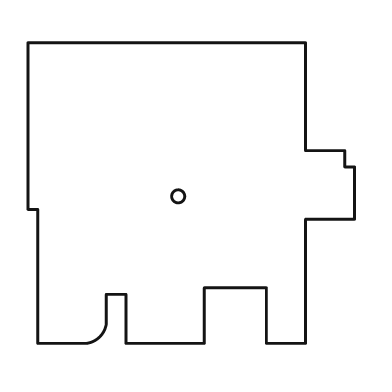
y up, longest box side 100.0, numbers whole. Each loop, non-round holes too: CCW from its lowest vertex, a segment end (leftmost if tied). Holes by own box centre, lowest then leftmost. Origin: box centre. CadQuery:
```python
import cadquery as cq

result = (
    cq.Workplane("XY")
    .moveTo(-47.0, -46.0)
    .lineTo(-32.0, -46.0)
    .threePointArc((-28.0, -44.0), (-26.0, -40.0))
    .lineTo(-26.0, -31.0)
    .lineTo(-20.0, -31.0)
    .lineTo(-20.0, -46.0)
    .lineTo(4.0, -46.0)
    .lineTo(4.0, -29.0)
    .lineTo(23.0, -29.0)
    .lineTo(23.0, -46.0)
    .lineTo(35.0, -46.0)
    .lineTo(35.0, -8.0)
    .lineTo(50.0, -8.0)
    .lineTo(50.0, 8.0)
    .lineTo(47.0, 8.0)
    .lineTo(47.0, 13.0)
    .lineTo(35.0, 13.0)
    .lineTo(35.0, 46.0)
    .lineTo(-50.0, 46.0)
    .lineTo(-50.0, -5.0)
    .lineTo(-47.0, -5.0)
    .close()
    .moveTo(-4.0, -1.0)
    .circle(2.0)
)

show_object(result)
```